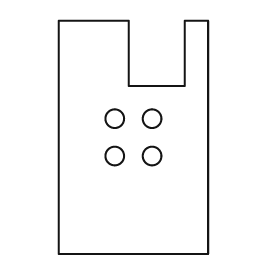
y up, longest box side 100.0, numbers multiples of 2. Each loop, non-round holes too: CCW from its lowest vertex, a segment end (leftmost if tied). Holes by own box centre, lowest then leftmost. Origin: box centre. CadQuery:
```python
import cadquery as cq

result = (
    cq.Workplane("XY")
    .moveTo(-32.0, -50.0)
    .lineTo(32.0, -50.0)
    .lineTo(32.0, 50.0)
    .lineTo(22.0, 50.0)
    .lineTo(22.0, 22.0)
    .lineTo(-2.0, 22.0)
    .lineTo(-2.0, 50.0)
    .lineTo(-32.0, 50.0)
    .close()
    .moveTo(-8.0, -8.0)
    .circle(4.0)
    .moveTo(8.0, -8.0)
    .circle(4.0)
    .moveTo(-8.0, 8.0)
    .circle(4.0)
    .moveTo(8.0, 8.0)
    .circle(4.0)
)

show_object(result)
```